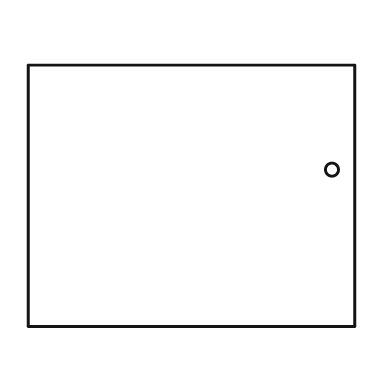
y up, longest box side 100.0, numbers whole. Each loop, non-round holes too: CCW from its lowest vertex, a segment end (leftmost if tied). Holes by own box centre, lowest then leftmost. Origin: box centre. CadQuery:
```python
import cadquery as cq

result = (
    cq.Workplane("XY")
    .moveTo(-50.0, -40.0)
    .lineTo(50.0, -40.0)
    .lineTo(50.0, 40.0)
    .lineTo(-50.0, 40.0)
    .close()
    .moveTo(43.0, 8.0)
    .circle(2.0)
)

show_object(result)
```